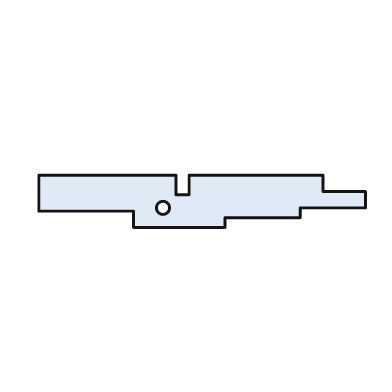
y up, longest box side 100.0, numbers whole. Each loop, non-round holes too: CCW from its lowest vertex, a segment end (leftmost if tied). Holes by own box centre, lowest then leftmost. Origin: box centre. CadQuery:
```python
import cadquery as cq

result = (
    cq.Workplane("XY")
    .moveTo(-21.0, -8.0)
    .lineTo(7.0, -8.0)
    .lineTo(7.0, -5.0)
    .lineTo(30.0, -5.0)
    .lineTo(30.0, -2.0)
    .lineTo(50.0, -2.0)
    .lineTo(50.0, 3.0)
    .lineTo(37.0, 3.0)
    .lineTo(37.0, 8.0)
    .lineTo(-4.0, 8.0)
    .lineTo(-4.0, 2.0)
    .lineTo(-8.0, 2.0)
    .lineTo(-8.0, 8.0)
    .lineTo(-50.0, 8.0)
    .lineTo(-50.0, -3.0)
    .lineTo(-21.0, -3.0)
    .close()
    .moveTo(-12.0, -2.0)
    .circle(2.0)
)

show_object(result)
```